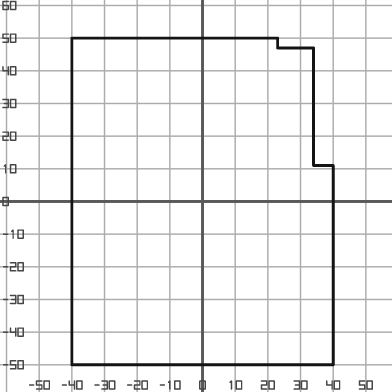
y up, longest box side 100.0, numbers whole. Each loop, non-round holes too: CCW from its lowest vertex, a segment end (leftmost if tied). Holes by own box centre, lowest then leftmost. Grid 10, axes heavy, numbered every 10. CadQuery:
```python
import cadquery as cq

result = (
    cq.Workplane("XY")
    .moveTo(-40.0, -50.0)
    .lineTo(40.0, -50.0)
    .lineTo(40.0, 11.0)
    .lineTo(34.0, 11.0)
    .lineTo(34.0, 47.0)
    .lineTo(23.0, 47.0)
    .lineTo(23.0, 50.0)
    .lineTo(-40.0, 50.0)
    .close()
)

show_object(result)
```